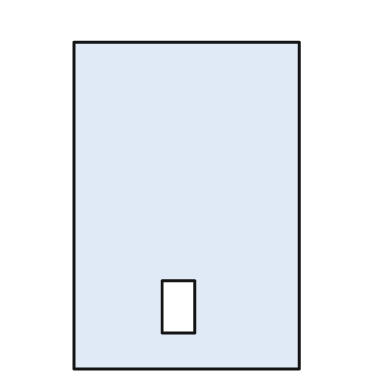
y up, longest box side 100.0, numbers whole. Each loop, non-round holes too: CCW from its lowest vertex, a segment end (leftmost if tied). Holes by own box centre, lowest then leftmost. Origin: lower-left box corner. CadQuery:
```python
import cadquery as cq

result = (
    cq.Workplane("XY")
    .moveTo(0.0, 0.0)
    .lineTo(69.0, 0.0)
    .lineTo(69.0, 100.0)
    .lineTo(0.0, 100.0)
    .close()
    .moveTo(27.0, 11.0)
    .lineTo(37.0, 11.0)
    .lineTo(37.0, 27.0)
    .lineTo(27.0, 27.0)
    .close()
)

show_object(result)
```